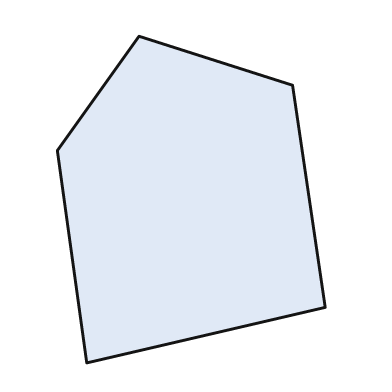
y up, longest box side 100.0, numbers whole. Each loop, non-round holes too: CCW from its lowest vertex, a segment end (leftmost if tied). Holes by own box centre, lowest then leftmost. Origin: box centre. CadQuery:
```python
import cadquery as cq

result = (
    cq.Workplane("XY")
    .moveTo(-32.0, -50.0)
    .lineTo(41.0, -33.0)
    .lineTo(31.0, 35.0)
    .lineTo(-16.0, 50.0)
    .lineTo(-41.0, 15.0)
    .close()
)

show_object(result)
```